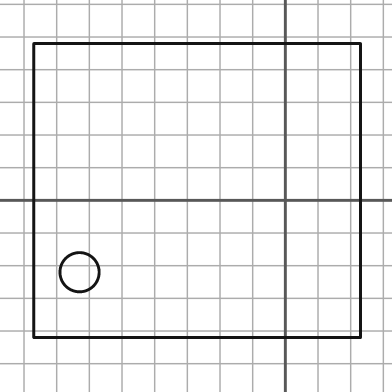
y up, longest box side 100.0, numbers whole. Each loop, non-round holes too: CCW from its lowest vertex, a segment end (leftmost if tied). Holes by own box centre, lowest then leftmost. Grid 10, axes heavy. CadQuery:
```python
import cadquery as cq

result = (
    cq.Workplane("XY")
    .moveTo(-77.0, -42.0)
    .lineTo(23.0, -42.0)
    .lineTo(23.0, 48.0)
    .lineTo(-77.0, 48.0)
    .close()
    .moveTo(-63.0, -22.0)
    .circle(6.0)
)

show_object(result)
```